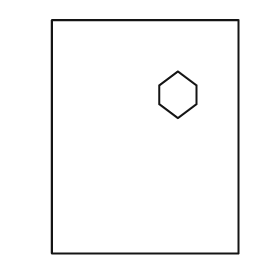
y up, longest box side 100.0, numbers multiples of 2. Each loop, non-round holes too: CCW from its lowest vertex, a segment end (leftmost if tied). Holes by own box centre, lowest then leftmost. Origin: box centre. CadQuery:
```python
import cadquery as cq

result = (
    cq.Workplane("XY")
    .moveTo(-40.0, -50.0)
    .lineTo(40.0, -50.0)
    .lineTo(40.0, 50.0)
    .lineTo(-40.0, 50.0)
    .close()
    .moveTo(14.0, 8.0)
    .lineTo(22.0, 14.0)
    .lineTo(22.0, 22.0)
    .lineTo(14.0, 28.0)
    .lineTo(6.0, 22.0)
    .lineTo(6.0, 14.0)
    .close()
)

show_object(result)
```